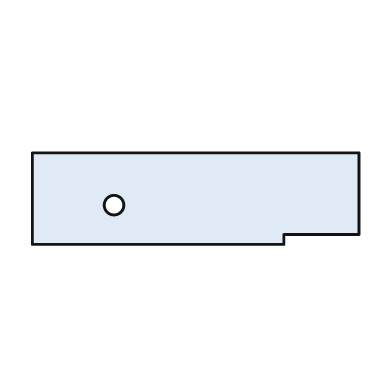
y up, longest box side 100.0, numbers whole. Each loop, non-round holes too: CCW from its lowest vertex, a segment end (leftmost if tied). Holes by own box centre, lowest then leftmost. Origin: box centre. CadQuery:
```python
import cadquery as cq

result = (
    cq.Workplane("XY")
    .moveTo(-50.0, -14.0)
    .lineTo(27.0, -14.0)
    .lineTo(27.0, -11.0)
    .lineTo(50.0, -11.0)
    .lineTo(50.0, 14.0)
    .lineTo(-50.0, 14.0)
    .close()
    .moveTo(-25.0, -2.0)
    .circle(3.0)
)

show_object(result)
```